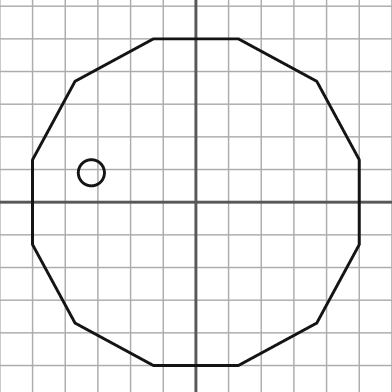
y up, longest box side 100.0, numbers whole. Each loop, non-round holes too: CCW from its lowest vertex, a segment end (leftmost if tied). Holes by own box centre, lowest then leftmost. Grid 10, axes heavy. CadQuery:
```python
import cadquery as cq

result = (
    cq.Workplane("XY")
    .moveTo(-13.0, -50.0)
    .lineTo(13.0, -50.0)
    .lineTo(37.0, -37.0)
    .lineTo(50.0, -13.0)
    .lineTo(50.0, 13.0)
    .lineTo(37.0, 37.0)
    .lineTo(13.0, 50.0)
    .lineTo(-13.0, 50.0)
    .lineTo(-37.0, 37.0)
    .lineTo(-50.0, 13.0)
    .lineTo(-50.0, -13.0)
    .lineTo(-37.0, -37.0)
    .close()
    .moveTo(-32.0, 9.0)
    .circle(4.0)
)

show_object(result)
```